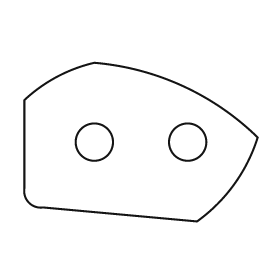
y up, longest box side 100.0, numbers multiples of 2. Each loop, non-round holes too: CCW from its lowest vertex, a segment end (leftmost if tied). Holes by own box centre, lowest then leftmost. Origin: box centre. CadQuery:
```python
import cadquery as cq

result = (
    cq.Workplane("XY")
    .moveTo(24.0, -34.0)
    .threePointArc((40.0, -18.0), (50.0, 2.0))
    .threePointArc((18.0, 24.0), (-20.0, 34.0))
    .threePointArc((-36.0, 28.0), (-50.0, 18.0))
    .lineTo(-50.0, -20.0)
    .threePointArc((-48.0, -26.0), (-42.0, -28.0))
    .close()
    .moveTo(-20.0, 0.0)
    .circle(8.0)
    .moveTo(20.0, 0.0)
    .circle(8.0)
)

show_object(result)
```